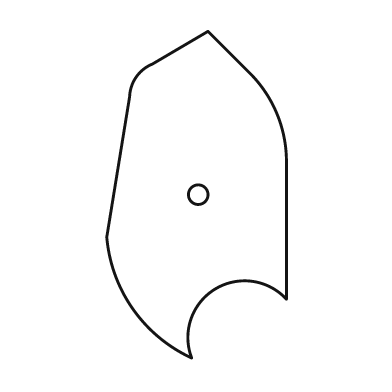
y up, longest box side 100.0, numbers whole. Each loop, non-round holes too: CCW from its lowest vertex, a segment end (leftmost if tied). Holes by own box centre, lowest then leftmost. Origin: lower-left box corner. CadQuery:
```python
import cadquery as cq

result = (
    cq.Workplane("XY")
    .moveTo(26.0, 0.0)
    .threePointArc((33.0, 21.0), (55.0, 18.0))
    .lineTo(55.0, 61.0)
    .threePointArc((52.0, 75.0), (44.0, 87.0))
    .lineTo(31.0, 100.0)
    .lineTo(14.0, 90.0)
    .threePointArc((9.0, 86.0), (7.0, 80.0))
    .lineTo(0.0, 37.0)
    .threePointArc((8.0, 15.0), (26.0, 0.0))
    .close()
    .moveTo(28.0, 50.0)
    .circle(3.0)
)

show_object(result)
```